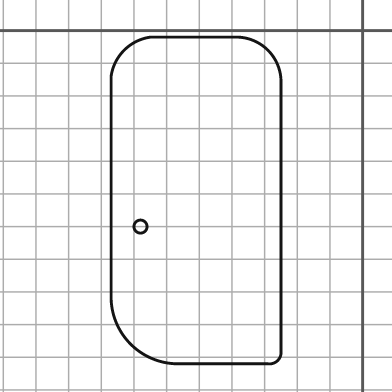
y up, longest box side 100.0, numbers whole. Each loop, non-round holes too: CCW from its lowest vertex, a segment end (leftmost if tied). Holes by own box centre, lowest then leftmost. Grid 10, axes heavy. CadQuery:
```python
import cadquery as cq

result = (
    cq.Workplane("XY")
    .moveTo(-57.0, -102.0)
    .lineTo(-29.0, -102.0)
    .threePointArc((-26.0, -101.0), (-25.0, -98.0))
    .lineTo(-25.0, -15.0)
    .threePointArc((-29.0, -6.0), (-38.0, -2.0))
    .lineTo(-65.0, -2.0)
    .threePointArc((-73.0, -6.0), (-77.0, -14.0))
    .lineTo(-77.0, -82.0)
    .threePointArc((-71.0, -96.0), (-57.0, -102.0))
    .close()
    .moveTo(-68.0, -60.0)
    .circle(2.0)
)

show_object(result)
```